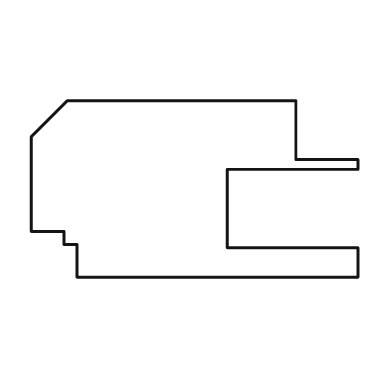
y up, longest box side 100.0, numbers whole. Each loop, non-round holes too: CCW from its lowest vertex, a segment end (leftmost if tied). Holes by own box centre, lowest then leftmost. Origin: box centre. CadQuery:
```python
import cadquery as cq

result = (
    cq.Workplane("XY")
    .moveTo(-36.0, -27.0)
    .lineTo(50.0, -27.0)
    .lineTo(50.0, -18.0)
    .lineTo(10.0, -18.0)
    .lineTo(10.0, 6.0)
    .lineTo(50.0, 6.0)
    .lineTo(50.0, 9.0)
    .lineTo(31.0, 9.0)
    .lineTo(31.0, 27.0)
    .lineTo(-39.0, 27.0)
    .lineTo(-50.0, 16.0)
    .lineTo(-50.0, -13.0)
    .lineTo(-40.0, -13.0)
    .lineTo(-40.0, -17.0)
    .lineTo(-36.0, -17.0)
    .close()
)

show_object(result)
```